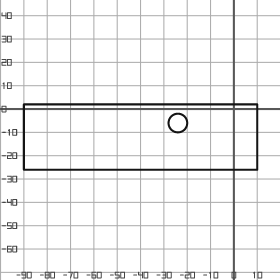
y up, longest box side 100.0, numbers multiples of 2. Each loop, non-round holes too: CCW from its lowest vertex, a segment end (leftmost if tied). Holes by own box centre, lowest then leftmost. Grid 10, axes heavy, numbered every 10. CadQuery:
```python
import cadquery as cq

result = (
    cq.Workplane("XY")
    .moveTo(-90.0, -26.0)
    .lineTo(10.0, -26.0)
    .lineTo(10.0, 2.0)
    .lineTo(-90.0, 2.0)
    .close()
    .moveTo(-24.0, -6.0)
    .circle(4.0)
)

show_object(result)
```